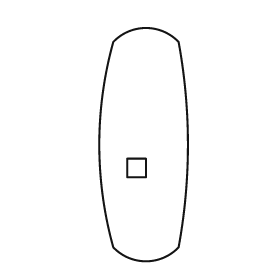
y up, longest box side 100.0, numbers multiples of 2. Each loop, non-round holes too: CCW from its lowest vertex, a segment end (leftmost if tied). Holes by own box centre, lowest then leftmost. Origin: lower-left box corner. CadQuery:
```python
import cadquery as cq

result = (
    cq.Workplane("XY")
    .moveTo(6.0, 6.0)
    .threePointArc((20.0, 0.0), (34.0, 6.0))
    .threePointArc((38.0, 50.0), (34.0, 94.0))
    .threePointArc((20.0, 100.0), (6.0, 94.0))
    .threePointArc((0.0, 50.0), (6.0, 6.0))
    .close()
    .moveTo(12.0, 36.0)
    .lineTo(20.0, 36.0)
    .lineTo(20.0, 44.0)
    .lineTo(12.0, 44.0)
    .close()
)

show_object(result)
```